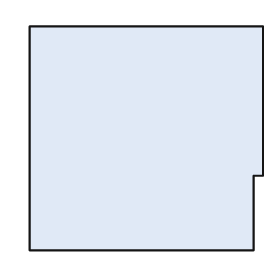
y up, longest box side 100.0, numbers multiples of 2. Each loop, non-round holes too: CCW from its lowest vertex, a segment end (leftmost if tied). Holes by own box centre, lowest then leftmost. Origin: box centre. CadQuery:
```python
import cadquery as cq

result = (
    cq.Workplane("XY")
    .moveTo(-50.0, -48.0)
    .lineTo(46.0, -48.0)
    .lineTo(46.0, -16.0)
    .lineTo(50.0, -16.0)
    .lineTo(50.0, 48.0)
    .lineTo(-50.0, 48.0)
    .close()
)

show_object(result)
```